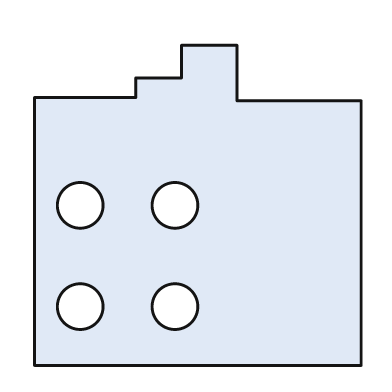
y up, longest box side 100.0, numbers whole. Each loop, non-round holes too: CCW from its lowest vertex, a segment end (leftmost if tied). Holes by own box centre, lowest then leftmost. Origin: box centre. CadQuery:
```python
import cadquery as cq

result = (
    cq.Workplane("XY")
    .moveTo(-50.0, -49.0)
    .lineTo(50.0, -49.0)
    .lineTo(50.0, 32.0)
    .lineTo(12.0, 32.0)
    .lineTo(12.0, 49.0)
    .lineTo(-5.0, 49.0)
    .lineTo(-5.0, 39.0)
    .lineTo(-19.0, 39.0)
    .lineTo(-19.0, 33.0)
    .lineTo(-50.0, 33.0)
    .close()
    .moveTo(-36.0, -31.0)
    .circle(7.0)
    .moveTo(-7.0, -31.0)
    .circle(7.0)
    .moveTo(-36.0, 0.0)
    .circle(7.0)
    .moveTo(-7.0, 0.0)
    .circle(7.0)
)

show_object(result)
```